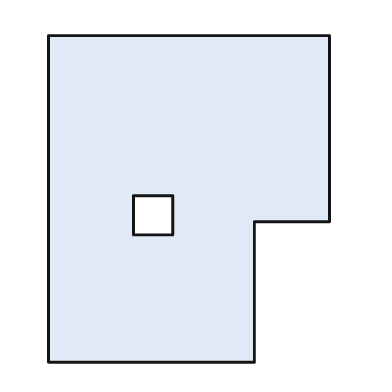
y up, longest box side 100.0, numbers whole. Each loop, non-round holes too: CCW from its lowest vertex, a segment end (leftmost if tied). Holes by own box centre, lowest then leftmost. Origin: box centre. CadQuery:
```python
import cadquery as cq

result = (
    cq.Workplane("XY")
    .moveTo(-43.0, -50.0)
    .lineTo(20.0, -50.0)
    .lineTo(20.0, -7.0)
    .lineTo(43.0, -7.0)
    .lineTo(43.0, 50.0)
    .lineTo(-43.0, 50.0)
    .close()
    .moveTo(-17.0, -11.0)
    .lineTo(-5.0, -11.0)
    .lineTo(-5.0, 1.0)
    .lineTo(-17.0, 1.0)
    .close()
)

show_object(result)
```